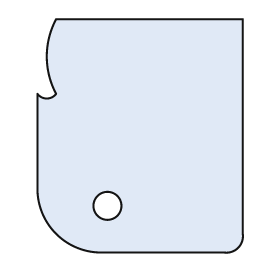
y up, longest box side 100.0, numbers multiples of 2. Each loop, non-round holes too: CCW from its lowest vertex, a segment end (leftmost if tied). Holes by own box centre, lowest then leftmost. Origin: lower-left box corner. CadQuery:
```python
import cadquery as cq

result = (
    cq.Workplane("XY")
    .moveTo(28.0, 0.0)
    .lineTo(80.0, 0.0)
    .threePointArc((86.0, 2.0), (88.0, 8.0))
    .lineTo(88.0, 100.0)
    .lineTo(8.0, 100.0)
    .threePointArc((4.0, 84.0), (8.0, 68.0))
    .threePointArc((4.0, 66.0), (0.0, 68.0))
    .lineTo(0.0, 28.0)
    .threePointArc((8.0, 8.0), (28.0, 0.0))
    .close()
    .moveTo(30.0, 20.0)
    .circle(6.0)
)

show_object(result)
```